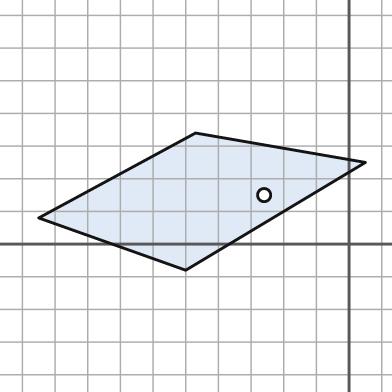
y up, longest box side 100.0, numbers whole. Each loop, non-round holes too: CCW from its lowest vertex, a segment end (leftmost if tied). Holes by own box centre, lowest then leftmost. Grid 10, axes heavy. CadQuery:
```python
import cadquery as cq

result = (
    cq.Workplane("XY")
    .moveTo(-50.0, -8.0)
    .lineTo(5.0, 25.0)
    .lineTo(-47.0, 34.0)
    .lineTo(-95.0, 8.0)
    .close()
    .moveTo(-26.0, 15.0)
    .circle(2.0)
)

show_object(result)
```